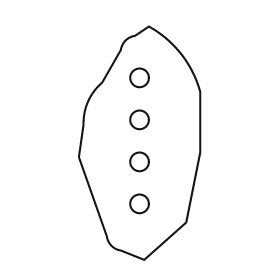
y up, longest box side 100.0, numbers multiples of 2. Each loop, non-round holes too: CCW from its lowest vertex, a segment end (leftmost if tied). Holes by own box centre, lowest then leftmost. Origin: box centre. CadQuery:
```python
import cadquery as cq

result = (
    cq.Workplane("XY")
    .moveTo(2.0, -50.0)
    .lineTo(20.0, -34.0)
    .lineTo(26.0, -4.0)
    .lineTo(26.0, 22.0)
    .threePointArc((18.0, 38.0), (4.0, 50.0))
    .lineTo(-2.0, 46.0)
    .threePointArc((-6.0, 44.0), (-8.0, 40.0))
    .lineTo(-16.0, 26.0)
    .threePointArc((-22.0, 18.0), (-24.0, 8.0))
    .lineTo(-26.0, -6.0)
    .lineTo(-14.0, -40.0)
    .threePointArc((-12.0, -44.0), (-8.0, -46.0))
    .close()
    .moveTo(0.0, -26.0)
    .circle(4.0)
    .moveTo(0.0, -8.0)
    .circle(4.0)
    .moveTo(0.0, 10.0)
    .circle(4.0)
    .moveTo(0.0, 28.0)
    .circle(4.0)
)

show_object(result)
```